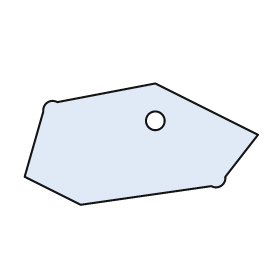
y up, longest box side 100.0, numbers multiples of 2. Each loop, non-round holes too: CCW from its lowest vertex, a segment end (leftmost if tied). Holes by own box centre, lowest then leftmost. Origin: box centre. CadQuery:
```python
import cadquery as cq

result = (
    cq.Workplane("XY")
    .moveTo(-26.0, -26.0)
    .lineTo(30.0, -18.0)
    .threePointArc((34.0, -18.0), (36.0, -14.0))
    .lineTo(50.0, 4.0)
    .lineTo(6.0, 26.0)
    .lineTo(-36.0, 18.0)
    .threePointArc((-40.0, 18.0), (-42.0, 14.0))
    .lineTo(-50.0, -14.0)
    .close()
    .moveTo(6.0, 10.0)
    .circle(4.0)
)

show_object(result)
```